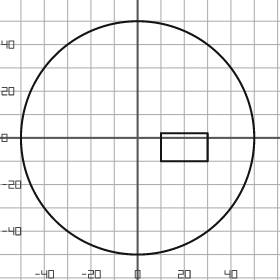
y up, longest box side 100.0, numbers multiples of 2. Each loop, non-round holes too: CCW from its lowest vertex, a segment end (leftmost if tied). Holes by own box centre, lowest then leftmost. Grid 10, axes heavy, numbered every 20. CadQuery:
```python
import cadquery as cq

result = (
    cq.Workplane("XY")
    .moveTo(0.0, 0.0)
    .circle(50.0)
    .moveTo(10.0, -10.0)
    .lineTo(30.0, -10.0)
    .lineTo(30.0, 2.0)
    .lineTo(10.0, 2.0)
    .close()
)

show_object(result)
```